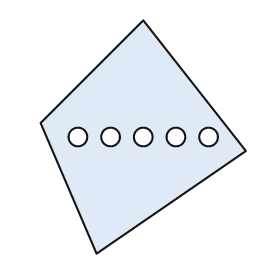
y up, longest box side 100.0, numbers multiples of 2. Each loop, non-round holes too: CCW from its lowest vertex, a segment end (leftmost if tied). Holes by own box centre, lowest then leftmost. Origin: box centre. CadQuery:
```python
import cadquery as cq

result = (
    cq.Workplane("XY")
    .moveTo(-20.0, -50.0)
    .lineTo(44.0, -6.0)
    .lineTo(0.0, 50.0)
    .lineTo(-44.0, 6.0)
    .close()
    .moveTo(-28.0, 0.0)
    .circle(4.0)
    .moveTo(-14.0, 0.0)
    .circle(4.0)
    .moveTo(0.0, 0.0)
    .circle(4.0)
    .moveTo(14.0, 0.0)
    .circle(4.0)
    .moveTo(28.0, 0.0)
    .circle(4.0)
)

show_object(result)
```